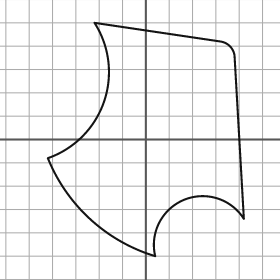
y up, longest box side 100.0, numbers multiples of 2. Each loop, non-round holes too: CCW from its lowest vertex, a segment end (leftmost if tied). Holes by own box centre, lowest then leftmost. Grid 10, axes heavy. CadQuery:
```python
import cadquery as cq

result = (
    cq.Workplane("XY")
    .moveTo(4.0, -50.0)
    .threePointArc((16.0, -26.0), (42.0, -34.0))
    .lineTo(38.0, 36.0)
    .threePointArc((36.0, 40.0), (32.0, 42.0))
    .lineTo(-22.0, 50.0)
    .threePointArc((-18.0, 16.0), (-42.0, -8.0))
    .threePointArc((-24.0, -34.0), (4.0, -50.0))
    .close()
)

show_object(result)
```